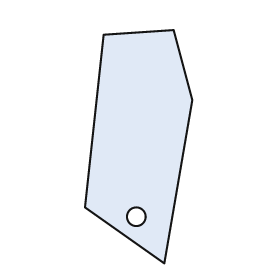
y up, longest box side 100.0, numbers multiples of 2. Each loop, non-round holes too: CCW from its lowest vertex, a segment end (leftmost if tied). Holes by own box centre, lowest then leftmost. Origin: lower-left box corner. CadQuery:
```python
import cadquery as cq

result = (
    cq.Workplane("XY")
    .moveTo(34.0, 0.0)
    .lineTo(46.0, 70.0)
    .lineTo(38.0, 100.0)
    .lineTo(8.0, 98.0)
    .lineTo(0.0, 24.0)
    .close()
    .moveTo(22.0, 20.0)
    .circle(4.0)
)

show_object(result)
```